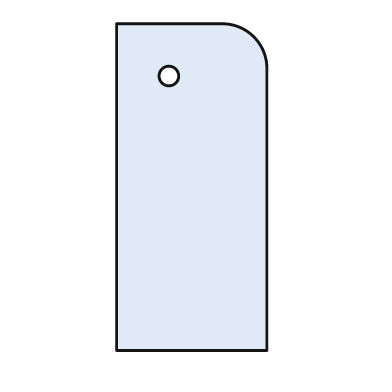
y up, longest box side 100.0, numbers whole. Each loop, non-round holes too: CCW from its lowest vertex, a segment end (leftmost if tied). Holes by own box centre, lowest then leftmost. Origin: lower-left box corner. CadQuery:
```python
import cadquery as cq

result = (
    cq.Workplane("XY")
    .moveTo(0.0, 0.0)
    .lineTo(46.0, 0.0)
    .lineTo(46.0, 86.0)
    .threePointArc((42.0, 96.0), (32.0, 100.0))
    .lineTo(0.0, 100.0)
    .close()
    .moveTo(16.0, 84.0)
    .circle(3.0)
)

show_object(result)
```